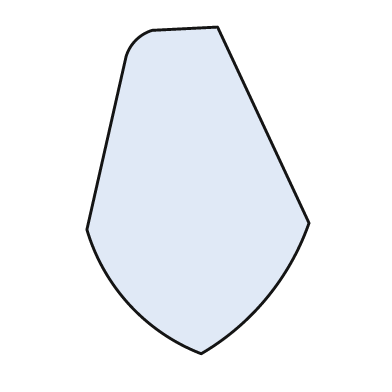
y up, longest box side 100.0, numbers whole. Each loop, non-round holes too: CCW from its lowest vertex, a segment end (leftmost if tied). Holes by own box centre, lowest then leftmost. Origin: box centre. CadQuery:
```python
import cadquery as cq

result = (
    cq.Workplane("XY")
    .moveTo(1.0, -50.0)
    .threePointArc((21.0, -33.0), (34.0, -10.0))
    .lineTo(6.0, 50.0)
    .lineTo(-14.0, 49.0)
    .threePointArc((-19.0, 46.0), (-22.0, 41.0))
    .lineTo(-34.0, -12.0)
    .threePointArc((-21.0, -35.0), (1.0, -50.0))
    .close()
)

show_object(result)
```